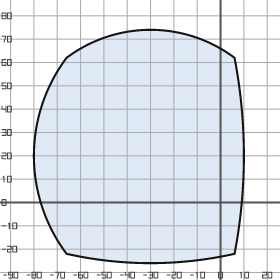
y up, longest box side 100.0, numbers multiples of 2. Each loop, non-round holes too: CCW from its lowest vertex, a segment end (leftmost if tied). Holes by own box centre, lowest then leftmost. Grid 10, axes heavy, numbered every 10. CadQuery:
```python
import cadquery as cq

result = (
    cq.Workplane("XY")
    .moveTo(-66.0, -22.0)
    .threePointArc((-30.0, -26.0), (6.0, -22.0))
    .threePointArc((10.0, 20.0), (6.0, 62.0))
    .threePointArc((-30.0, 74.0), (-66.0, 62.0))
    .threePointArc((-80.0, 20.0), (-66.0, -22.0))
    .close()
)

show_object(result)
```